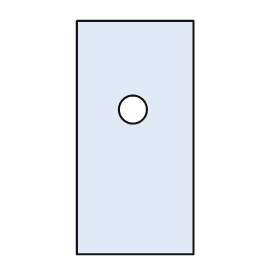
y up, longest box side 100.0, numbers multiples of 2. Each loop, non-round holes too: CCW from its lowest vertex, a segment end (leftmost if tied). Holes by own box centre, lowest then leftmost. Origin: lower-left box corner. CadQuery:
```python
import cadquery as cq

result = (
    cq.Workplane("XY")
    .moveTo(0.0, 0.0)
    .lineTo(50.0, 0.0)
    .lineTo(50.0, 100.0)
    .lineTo(0.0, 100.0)
    .close()
    .moveTo(24.0, 62.0)
    .circle(6.0)
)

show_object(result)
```